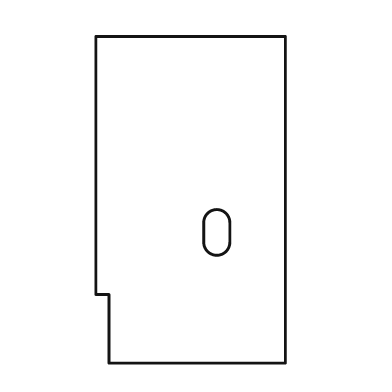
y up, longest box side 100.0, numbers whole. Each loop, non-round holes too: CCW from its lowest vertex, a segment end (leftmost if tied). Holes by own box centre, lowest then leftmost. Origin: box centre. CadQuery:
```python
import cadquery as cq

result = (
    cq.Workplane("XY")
    .moveTo(-25.0, -50.0)
    .lineTo(29.0, -50.0)
    .lineTo(29.0, 50.0)
    .lineTo(-29.0, 50.0)
    .lineTo(-29.0, -29.0)
    .lineTo(-25.0, -29.0)
    .close()
    .moveTo(4.0, -13.0)
    .threePointArc((8.0, -17.0), (12.0, -13.0))
    .lineTo(12.0, -7.0)
    .threePointArc((8.0, -3.0), (4.0, -7.0))
    .close()
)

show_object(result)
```